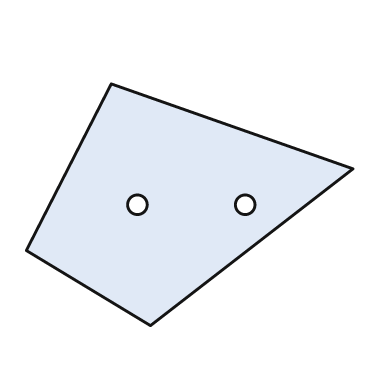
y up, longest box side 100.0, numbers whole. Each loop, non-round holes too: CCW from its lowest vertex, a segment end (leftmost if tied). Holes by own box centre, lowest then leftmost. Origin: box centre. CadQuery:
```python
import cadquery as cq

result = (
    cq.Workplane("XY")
    .moveTo(-12.0, -37.0)
    .lineTo(50.0, 11.0)
    .lineTo(-24.0, 37.0)
    .lineTo(-50.0, -14.0)
    .close()
    .moveTo(-16.0, 0.0)
    .circle(3.0)
    .moveTo(17.0, 0.0)
    .circle(3.0)
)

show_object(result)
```